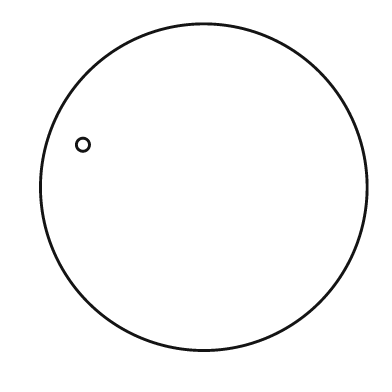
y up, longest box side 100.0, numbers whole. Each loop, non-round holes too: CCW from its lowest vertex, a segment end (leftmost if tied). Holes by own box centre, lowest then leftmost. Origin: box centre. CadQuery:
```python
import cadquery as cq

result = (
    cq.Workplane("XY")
    .moveTo(0.0, 0.0)
    .circle(50.0)
    .moveTo(-37.0, 13.0)
    .circle(2.0)
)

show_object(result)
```